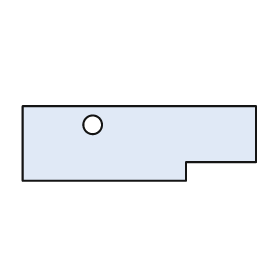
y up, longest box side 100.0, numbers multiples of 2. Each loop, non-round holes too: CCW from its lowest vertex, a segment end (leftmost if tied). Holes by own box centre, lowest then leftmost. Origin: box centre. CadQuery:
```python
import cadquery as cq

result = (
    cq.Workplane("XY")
    .moveTo(-50.0, -16.0)
    .lineTo(20.0, -16.0)
    .lineTo(20.0, -8.0)
    .lineTo(50.0, -8.0)
    .lineTo(50.0, 16.0)
    .lineTo(-50.0, 16.0)
    .close()
    .moveTo(-20.0, 8.0)
    .circle(4.0)
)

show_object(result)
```